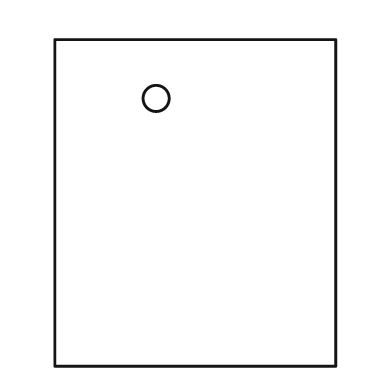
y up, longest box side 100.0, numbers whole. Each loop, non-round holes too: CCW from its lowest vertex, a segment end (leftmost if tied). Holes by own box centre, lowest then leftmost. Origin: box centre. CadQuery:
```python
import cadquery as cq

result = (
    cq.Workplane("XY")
    .moveTo(-43.0, -50.0)
    .lineTo(43.0, -50.0)
    .lineTo(43.0, 50.0)
    .lineTo(-43.0, 50.0)
    .close()
    .moveTo(-12.0, 32.0)
    .circle(4.0)
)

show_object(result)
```